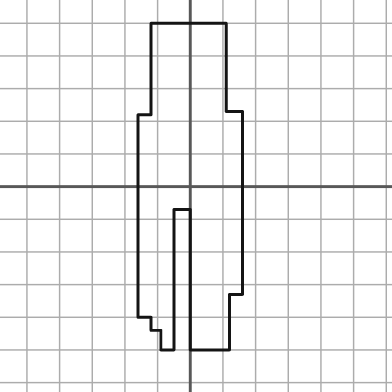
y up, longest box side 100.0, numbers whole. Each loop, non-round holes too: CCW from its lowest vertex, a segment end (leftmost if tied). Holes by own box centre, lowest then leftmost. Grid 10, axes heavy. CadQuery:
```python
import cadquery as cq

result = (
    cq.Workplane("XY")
    .moveTo(-9.0, -50.0)
    .lineTo(-5.0, -50.0)
    .lineTo(-5.0, -7.0)
    .lineTo(0.0, -7.0)
    .lineTo(0.0, -50.0)
    .lineTo(12.0, -50.0)
    .lineTo(12.0, -33.0)
    .lineTo(16.0, -33.0)
    .lineTo(16.0, 23.0)
    .lineTo(11.0, 23.0)
    .lineTo(11.0, 50.0)
    .lineTo(-12.0, 50.0)
    .lineTo(-12.0, 22.0)
    .lineTo(-16.0, 22.0)
    .lineTo(-16.0, -40.0)
    .lineTo(-12.0, -40.0)
    .lineTo(-12.0, -44.0)
    .lineTo(-9.0, -44.0)
    .close()
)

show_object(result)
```